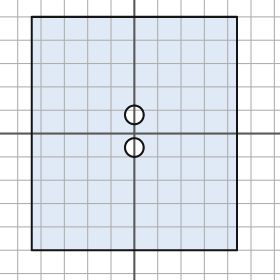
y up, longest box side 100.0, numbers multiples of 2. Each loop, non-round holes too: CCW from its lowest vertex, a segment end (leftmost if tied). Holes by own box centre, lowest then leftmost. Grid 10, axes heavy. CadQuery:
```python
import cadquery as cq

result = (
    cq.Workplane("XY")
    .moveTo(-44.0, -50.0)
    .lineTo(44.0, -50.0)
    .lineTo(44.0, 50.0)
    .lineTo(-44.0, 50.0)
    .close()
    .moveTo(0.0, -6.0)
    .circle(4.0)
    .moveTo(0.0, 8.0)
    .circle(4.0)
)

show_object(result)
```